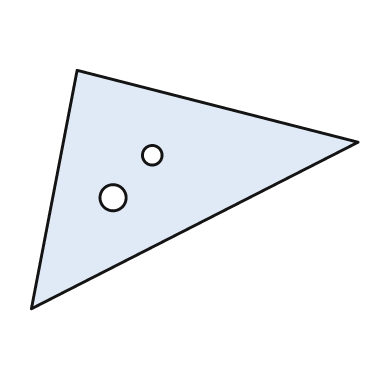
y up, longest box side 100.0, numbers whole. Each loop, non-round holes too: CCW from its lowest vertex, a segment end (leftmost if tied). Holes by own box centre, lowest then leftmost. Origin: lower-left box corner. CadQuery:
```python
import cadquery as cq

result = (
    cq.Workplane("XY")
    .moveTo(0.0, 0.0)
    .lineTo(100.0, 51.0)
    .lineTo(14.0, 73.0)
    .close()
    .moveTo(25.0, 34.0)
    .circle(4.0)
    .moveTo(37.0, 47.0)
    .circle(3.0)
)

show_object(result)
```